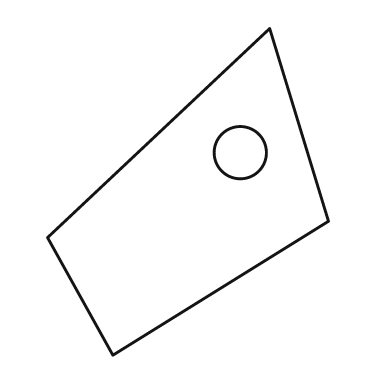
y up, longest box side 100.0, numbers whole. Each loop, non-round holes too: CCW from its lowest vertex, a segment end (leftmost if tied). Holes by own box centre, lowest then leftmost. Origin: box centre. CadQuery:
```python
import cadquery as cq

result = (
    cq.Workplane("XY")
    .moveTo(-23.0, -50.0)
    .lineTo(43.0, -9.0)
    .lineTo(25.0, 50.0)
    .lineTo(-43.0, -14.0)
    .close()
    .moveTo(16.0, 12.0)
    .circle(8.0)
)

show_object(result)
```